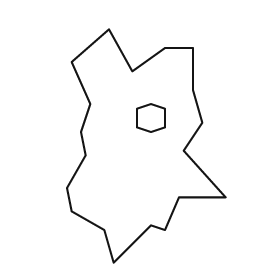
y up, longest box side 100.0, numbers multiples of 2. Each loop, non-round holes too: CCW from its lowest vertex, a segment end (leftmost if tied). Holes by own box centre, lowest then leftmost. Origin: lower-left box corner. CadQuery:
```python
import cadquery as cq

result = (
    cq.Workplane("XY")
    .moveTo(20.0, 0.0)
    .lineTo(36.0, 16.0)
    .lineTo(42.0, 14.0)
    .lineTo(48.0, 28.0)
    .lineTo(68.0, 28.0)
    .lineTo(50.0, 48.0)
    .lineTo(58.0, 60.0)
    .lineTo(54.0, 74.0)
    .lineTo(54.0, 92.0)
    .lineTo(42.0, 92.0)
    .lineTo(28.0, 82.0)
    .lineTo(18.0, 100.0)
    .lineTo(2.0, 86.0)
    .lineTo(10.0, 68.0)
    .lineTo(6.0, 56.0)
    .lineTo(8.0, 46.0)
    .lineTo(0.0, 32.0)
    .lineTo(2.0, 22.0)
    .lineTo(16.0, 14.0)
    .close()
    .moveTo(36.0, 56.0)
    .lineTo(42.0, 58.0)
    .lineTo(42.0, 66.0)
    .lineTo(36.0, 68.0)
    .lineTo(30.0, 66.0)
    .lineTo(30.0, 58.0)
    .close()
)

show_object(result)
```